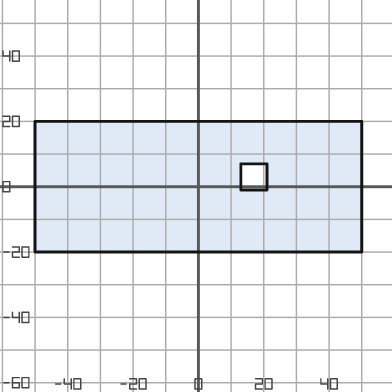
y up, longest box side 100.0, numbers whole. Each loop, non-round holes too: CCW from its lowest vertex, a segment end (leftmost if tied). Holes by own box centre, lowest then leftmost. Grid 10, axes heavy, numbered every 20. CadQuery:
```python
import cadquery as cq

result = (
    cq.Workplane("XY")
    .moveTo(-50.0, -20.0)
    .lineTo(50.0, -20.0)
    .lineTo(50.0, 20.0)
    .lineTo(-50.0, 20.0)
    .close()
    .moveTo(13.0, -1.0)
    .lineTo(21.0, -1.0)
    .lineTo(21.0, 7.0)
    .lineTo(13.0, 7.0)
    .close()
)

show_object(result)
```